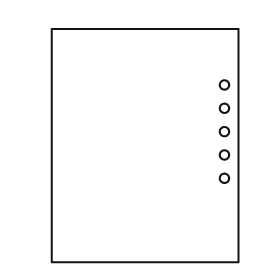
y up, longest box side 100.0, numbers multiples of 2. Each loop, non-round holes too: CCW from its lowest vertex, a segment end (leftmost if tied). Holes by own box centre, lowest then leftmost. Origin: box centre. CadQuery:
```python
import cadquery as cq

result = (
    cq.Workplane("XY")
    .moveTo(-40.0, -50.0)
    .lineTo(40.0, -50.0)
    .lineTo(40.0, 50.0)
    .lineTo(-40.0, 50.0)
    .close()
    .moveTo(34.0, -14.0)
    .circle(2.0)
    .moveTo(34.0, -4.0)
    .circle(2.0)
    .moveTo(34.0, 6.0)
    .circle(2.0)
    .moveTo(34.0, 16.0)
    .circle(2.0)
    .moveTo(34.0, 26.0)
    .circle(2.0)
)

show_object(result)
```